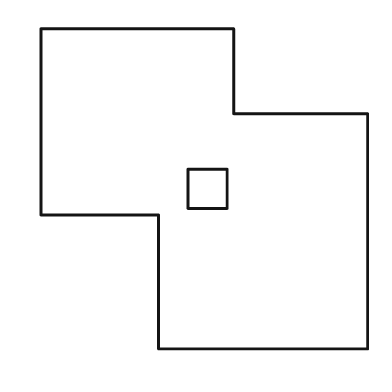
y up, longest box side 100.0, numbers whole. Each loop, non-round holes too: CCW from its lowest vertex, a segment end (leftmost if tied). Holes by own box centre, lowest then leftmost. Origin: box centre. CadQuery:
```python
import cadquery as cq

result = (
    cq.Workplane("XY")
    .moveTo(-14.0, -49.0)
    .lineTo(50.0, -49.0)
    .lineTo(50.0, 23.0)
    .lineTo(9.0, 23.0)
    .lineTo(9.0, 49.0)
    .lineTo(-50.0, 49.0)
    .lineTo(-50.0, -8.0)
    .lineTo(-14.0, -8.0)
    .close()
    .moveTo(-5.0, -6.0)
    .lineTo(7.0, -6.0)
    .lineTo(7.0, 6.0)
    .lineTo(-5.0, 6.0)
    .close()
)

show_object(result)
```